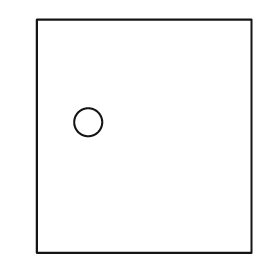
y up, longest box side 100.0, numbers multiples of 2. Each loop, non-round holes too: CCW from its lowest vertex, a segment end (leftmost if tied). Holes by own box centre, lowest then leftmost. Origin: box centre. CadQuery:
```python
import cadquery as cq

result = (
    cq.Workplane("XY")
    .moveTo(-46.0, -50.0)
    .lineTo(46.0, -50.0)
    .lineTo(46.0, 50.0)
    .lineTo(-46.0, 50.0)
    .close()
    .moveTo(-24.0, 6.0)
    .circle(6.0)
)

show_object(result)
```